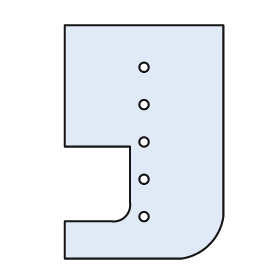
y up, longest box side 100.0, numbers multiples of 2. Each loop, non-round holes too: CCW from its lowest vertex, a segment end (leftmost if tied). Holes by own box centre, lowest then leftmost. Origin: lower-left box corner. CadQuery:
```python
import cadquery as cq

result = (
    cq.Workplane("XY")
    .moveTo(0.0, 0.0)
    .lineTo(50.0, 0.0)
    .threePointArc((62.0, 6.0), (68.0, 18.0))
    .lineTo(68.0, 100.0)
    .lineTo(0.0, 100.0)
    .lineTo(0.0, 48.0)
    .lineTo(28.0, 48.0)
    .lineTo(28.0, 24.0)
    .threePointArc((26.0, 18.0), (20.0, 16.0))
    .lineTo(0.0, 16.0)
    .close()
    .moveTo(34.0, 18.0)
    .circle(2.0)
    .moveTo(34.0, 34.0)
    .circle(2.0)
    .moveTo(34.0, 50.0)
    .circle(2.0)
    .moveTo(34.0, 66.0)
    .circle(2.0)
    .moveTo(34.0, 82.0)
    .circle(2.0)
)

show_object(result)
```